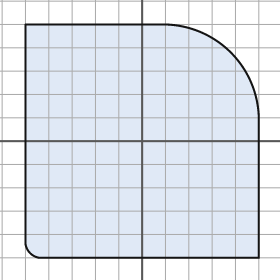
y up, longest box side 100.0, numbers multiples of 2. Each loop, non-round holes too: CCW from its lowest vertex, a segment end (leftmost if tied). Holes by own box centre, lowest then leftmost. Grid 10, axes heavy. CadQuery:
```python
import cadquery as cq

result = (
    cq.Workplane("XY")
    .moveTo(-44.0, -50.0)
    .lineTo(50.0, -50.0)
    .lineTo(50.0, 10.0)
    .threePointArc((38.0, 38.0), (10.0, 50.0))
    .lineTo(-50.0, 50.0)
    .lineTo(-50.0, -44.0)
    .threePointArc((-48.0, -48.0), (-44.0, -50.0))
    .close()
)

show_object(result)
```